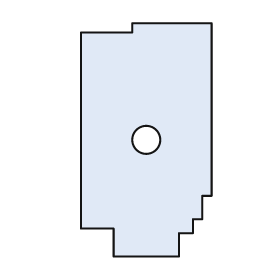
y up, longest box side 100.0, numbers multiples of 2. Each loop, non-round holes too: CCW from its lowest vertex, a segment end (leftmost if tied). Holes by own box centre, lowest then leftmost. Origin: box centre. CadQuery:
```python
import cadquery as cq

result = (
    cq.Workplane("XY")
    .moveTo(-14.0, -50.0)
    .lineTo(14.0, -50.0)
    .lineTo(14.0, -40.0)
    .lineTo(20.0, -40.0)
    .lineTo(20.0, -34.0)
    .lineTo(24.0, -34.0)
    .lineTo(24.0, -24.0)
    .lineTo(28.0, -24.0)
    .lineTo(28.0, 50.0)
    .lineTo(-6.0, 50.0)
    .lineTo(-6.0, 46.0)
    .lineTo(-28.0, 46.0)
    .lineTo(-28.0, -38.0)
    .lineTo(-14.0, -38.0)
    .close()
    .moveTo(0.0, 0.0)
    .circle(6.0)
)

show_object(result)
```